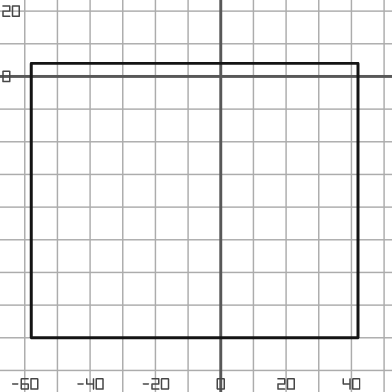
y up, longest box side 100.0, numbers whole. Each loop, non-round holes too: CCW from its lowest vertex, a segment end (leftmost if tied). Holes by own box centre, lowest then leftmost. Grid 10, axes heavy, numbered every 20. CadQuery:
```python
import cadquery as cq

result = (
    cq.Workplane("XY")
    .moveTo(-58.0, -80.0)
    .lineTo(42.0, -80.0)
    .lineTo(42.0, 4.0)
    .lineTo(-58.0, 4.0)
    .close()
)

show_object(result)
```